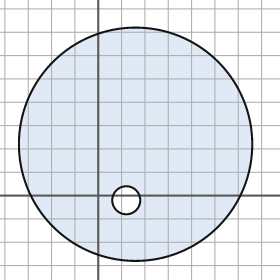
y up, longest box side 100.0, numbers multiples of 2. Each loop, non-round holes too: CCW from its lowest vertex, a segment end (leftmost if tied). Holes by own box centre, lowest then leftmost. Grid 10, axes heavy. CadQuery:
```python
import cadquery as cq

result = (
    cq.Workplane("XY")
    .moveTo(16.0, 22.0)
    .circle(50.0)
    .moveTo(12.0, -2.0)
    .circle(6.0)
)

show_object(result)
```